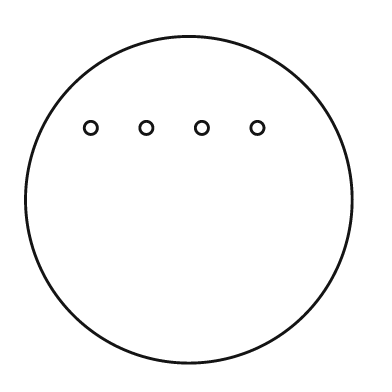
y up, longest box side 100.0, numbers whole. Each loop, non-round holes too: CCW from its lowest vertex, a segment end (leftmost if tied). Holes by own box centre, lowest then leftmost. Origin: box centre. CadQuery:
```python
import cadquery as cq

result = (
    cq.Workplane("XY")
    .moveTo(0.0, 0.0)
    .circle(50.0)
    .moveTo(-30.0, 22.0)
    .circle(2.0)
    .moveTo(-13.0, 22.0)
    .circle(2.0)
    .moveTo(4.0, 22.0)
    .circle(2.0)
    .moveTo(21.0, 22.0)
    .circle(2.0)
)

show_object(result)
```